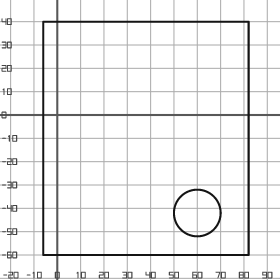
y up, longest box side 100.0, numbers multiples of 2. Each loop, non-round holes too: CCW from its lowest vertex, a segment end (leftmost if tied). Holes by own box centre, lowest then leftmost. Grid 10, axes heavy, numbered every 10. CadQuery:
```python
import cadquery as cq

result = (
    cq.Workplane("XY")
    .moveTo(-6.0, -60.0)
    .lineTo(82.0, -60.0)
    .lineTo(82.0, 40.0)
    .lineTo(-6.0, 40.0)
    .close()
    .moveTo(60.0, -42.0)
    .circle(10.0)
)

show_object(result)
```